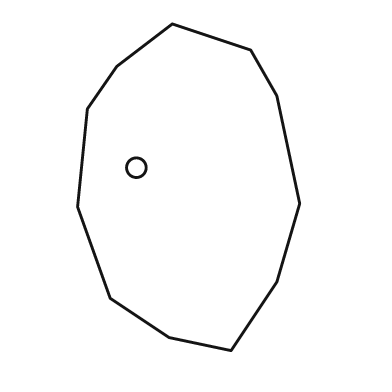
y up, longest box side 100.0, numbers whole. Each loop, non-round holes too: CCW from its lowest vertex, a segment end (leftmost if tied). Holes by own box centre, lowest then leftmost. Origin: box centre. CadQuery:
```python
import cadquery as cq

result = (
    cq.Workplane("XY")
    .moveTo(13.0, -50.0)
    .lineTo(27.0, -29.0)
    .lineTo(34.0, -5.0)
    .lineTo(27.0, 28.0)
    .lineTo(19.0, 42.0)
    .lineTo(-5.0, 50.0)
    .lineTo(-22.0, 37.0)
    .lineTo(-31.0, 24.0)
    .lineTo(-34.0, -6.0)
    .lineTo(-24.0, -34.0)
    .lineTo(-6.0, -46.0)
    .close()
    .moveTo(-16.0, 6.0)
    .circle(3.0)
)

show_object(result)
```